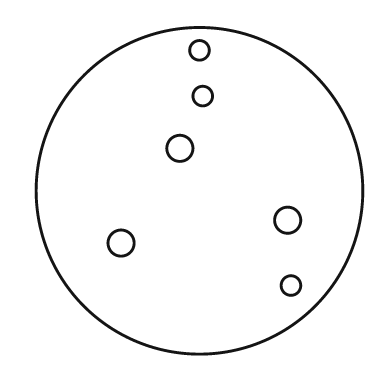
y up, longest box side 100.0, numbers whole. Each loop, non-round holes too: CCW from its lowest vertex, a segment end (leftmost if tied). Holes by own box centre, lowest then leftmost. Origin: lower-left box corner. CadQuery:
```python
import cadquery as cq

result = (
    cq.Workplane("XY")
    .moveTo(50.0, 50.0)
    .circle(50.0)
    .moveTo(78.0, 21.0)
    .circle(3.0)
    .moveTo(26.0, 34.0)
    .circle(4.0)
    .moveTo(77.0, 41.0)
    .circle(4.0)
    .moveTo(44.0, 63.0)
    .circle(4.0)
    .moveTo(51.0, 79.0)
    .circle(3.0)
    .moveTo(50.0, 93.0)
    .circle(3.0)
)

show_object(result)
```